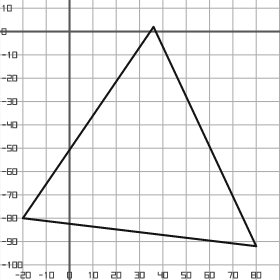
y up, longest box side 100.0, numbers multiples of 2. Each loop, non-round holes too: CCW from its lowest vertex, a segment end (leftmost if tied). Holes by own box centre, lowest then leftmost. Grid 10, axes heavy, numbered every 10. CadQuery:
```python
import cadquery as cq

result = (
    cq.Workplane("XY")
    .moveTo(80.0, -92.0)
    .lineTo(36.0, 2.0)
    .lineTo(-20.0, -80.0)
    .close()
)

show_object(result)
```